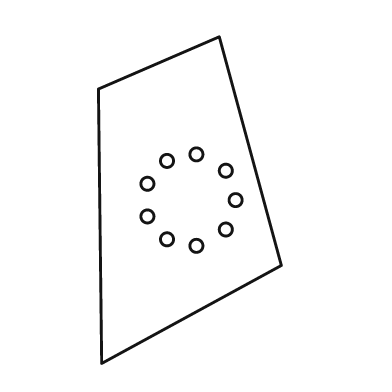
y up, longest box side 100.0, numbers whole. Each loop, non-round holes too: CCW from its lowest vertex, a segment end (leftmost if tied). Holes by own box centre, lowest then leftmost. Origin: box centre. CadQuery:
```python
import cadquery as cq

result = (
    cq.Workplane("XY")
    .moveTo(-27.0, -50.0)
    .lineTo(28.0, -20.0)
    .lineTo(9.0, 50.0)
    .lineTo(-28.0, 34.0)
    .close()
    .moveTo(2.0, -14.0)
    .circle(2.0)
    .moveTo(-7.0, -12.0)
    .circle(2.0)
    .moveTo(11.0, -9.0)
    .circle(2.0)
    .moveTo(-13.0, -5.0)
    .circle(2.0)
    .moveTo(14.0, 0.0)
    .circle(2.0)
    .moveTo(-13.0, 5.0)
    .circle(2.0)
    .moveTo(11.0, 9.0)
    .circle(2.0)
    .moveTo(-7.0, 12.0)
    .circle(2.0)
    .moveTo(2.0, 14.0)
    .circle(2.0)
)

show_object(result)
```